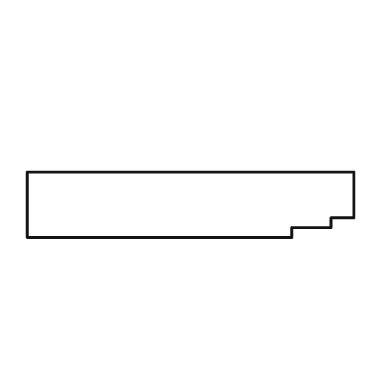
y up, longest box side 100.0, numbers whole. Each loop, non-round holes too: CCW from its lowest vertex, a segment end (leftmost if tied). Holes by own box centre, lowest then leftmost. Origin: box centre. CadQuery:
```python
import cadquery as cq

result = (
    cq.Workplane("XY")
    .moveTo(-50.0, -10.0)
    .lineTo(31.0, -10.0)
    .lineTo(31.0, -7.0)
    .lineTo(43.0, -7.0)
    .lineTo(43.0, -4.0)
    .lineTo(50.0, -4.0)
    .lineTo(50.0, 10.0)
    .lineTo(-50.0, 10.0)
    .close()
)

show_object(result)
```